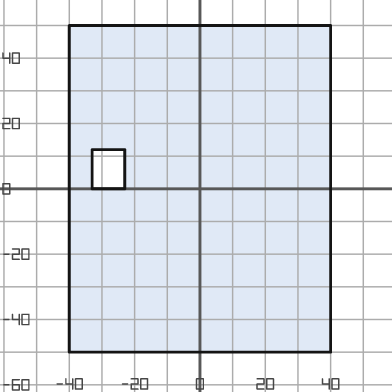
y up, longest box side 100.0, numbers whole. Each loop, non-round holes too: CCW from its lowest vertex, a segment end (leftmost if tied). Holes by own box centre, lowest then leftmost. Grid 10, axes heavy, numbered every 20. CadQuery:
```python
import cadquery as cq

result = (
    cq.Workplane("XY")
    .moveTo(-40.0, -50.0)
    .lineTo(40.0, -50.0)
    .lineTo(40.0, 50.0)
    .lineTo(-40.0, 50.0)
    .close()
    .moveTo(-33.0, 0.0)
    .lineTo(-23.0, 0.0)
    .lineTo(-23.0, 12.0)
    .lineTo(-33.0, 12.0)
    .close()
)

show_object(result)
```